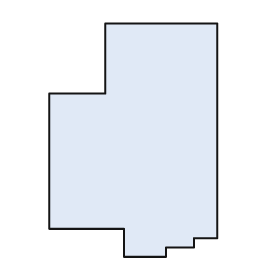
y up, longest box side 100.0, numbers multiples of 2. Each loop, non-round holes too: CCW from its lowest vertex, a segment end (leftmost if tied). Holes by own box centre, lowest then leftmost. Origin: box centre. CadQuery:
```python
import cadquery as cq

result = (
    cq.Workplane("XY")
    .moveTo(-4.0, -50.0)
    .lineTo(14.0, -50.0)
    .lineTo(14.0, -46.0)
    .lineTo(26.0, -46.0)
    .lineTo(26.0, -42.0)
    .lineTo(36.0, -42.0)
    .lineTo(36.0, 50.0)
    .lineTo(-12.0, 50.0)
    .lineTo(-12.0, 20.0)
    .lineTo(-36.0, 20.0)
    .lineTo(-36.0, -38.0)
    .lineTo(-4.0, -38.0)
    .close()
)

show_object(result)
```